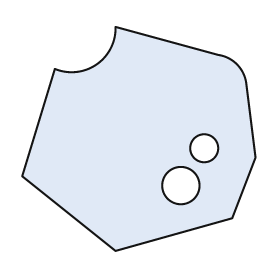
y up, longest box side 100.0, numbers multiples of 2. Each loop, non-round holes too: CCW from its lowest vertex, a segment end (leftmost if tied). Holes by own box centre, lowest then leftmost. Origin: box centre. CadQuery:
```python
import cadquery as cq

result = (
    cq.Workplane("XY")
    .moveTo(-10.0, -48.0)
    .lineTo(40.0, -34.0)
    .lineTo(50.0, -8.0)
    .lineTo(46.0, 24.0)
    .threePointArc((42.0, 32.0), (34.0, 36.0))
    .lineTo(-10.0, 48.0)
    .threePointArc((-18.0, 32.0), (-36.0, 30.0))
    .lineTo(-50.0, -16.0)
    .close()
    .moveTo(18.0, -20.0)
    .circle(8.0)
    .moveTo(28.0, -4.0)
    .circle(6.0)
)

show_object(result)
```